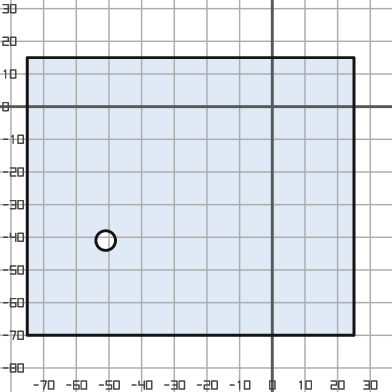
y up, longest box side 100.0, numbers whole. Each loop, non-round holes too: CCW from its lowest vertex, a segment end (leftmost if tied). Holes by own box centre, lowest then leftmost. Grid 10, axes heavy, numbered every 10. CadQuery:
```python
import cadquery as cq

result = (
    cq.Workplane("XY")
    .moveTo(-75.0, -70.0)
    .lineTo(25.0, -70.0)
    .lineTo(25.0, 15.0)
    .lineTo(-75.0, 15.0)
    .close()
    .moveTo(-51.0, -41.0)
    .circle(3.0)
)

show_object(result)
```